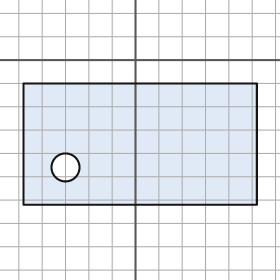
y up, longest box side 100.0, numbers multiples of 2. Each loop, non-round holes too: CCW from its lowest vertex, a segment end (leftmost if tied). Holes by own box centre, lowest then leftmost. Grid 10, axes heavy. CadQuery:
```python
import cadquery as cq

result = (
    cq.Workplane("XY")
    .moveTo(-48.0, -62.0)
    .lineTo(52.0, -62.0)
    .lineTo(52.0, -10.0)
    .lineTo(-48.0, -10.0)
    .close()
    .moveTo(-30.0, -46.0)
    .circle(6.0)
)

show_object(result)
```